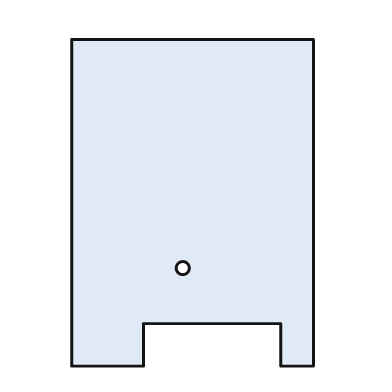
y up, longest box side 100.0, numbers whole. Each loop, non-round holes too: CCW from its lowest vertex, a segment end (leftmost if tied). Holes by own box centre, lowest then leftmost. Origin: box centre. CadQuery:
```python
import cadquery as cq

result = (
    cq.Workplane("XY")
    .moveTo(-37.0, -50.0)
    .lineTo(-15.0, -50.0)
    .lineTo(-15.0, -37.0)
    .lineTo(27.0, -37.0)
    .lineTo(27.0, -50.0)
    .lineTo(37.0, -50.0)
    .lineTo(37.0, 50.0)
    .lineTo(-37.0, 50.0)
    .close()
    .moveTo(-3.0, -20.0)
    .circle(2.0)
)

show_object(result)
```